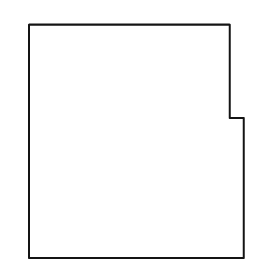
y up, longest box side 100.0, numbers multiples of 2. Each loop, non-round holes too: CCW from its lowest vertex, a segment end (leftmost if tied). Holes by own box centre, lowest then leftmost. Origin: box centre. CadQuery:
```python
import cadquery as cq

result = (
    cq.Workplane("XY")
    .moveTo(-46.0, -50.0)
    .lineTo(46.0, -50.0)
    .lineTo(46.0, 10.0)
    .lineTo(40.0, 10.0)
    .lineTo(40.0, 50.0)
    .lineTo(-46.0, 50.0)
    .close()
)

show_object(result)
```